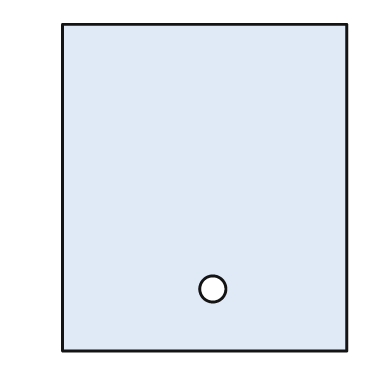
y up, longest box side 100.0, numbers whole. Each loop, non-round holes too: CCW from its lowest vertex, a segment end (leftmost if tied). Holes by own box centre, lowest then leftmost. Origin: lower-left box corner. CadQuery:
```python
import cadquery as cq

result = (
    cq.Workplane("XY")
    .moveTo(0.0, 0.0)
    .lineTo(87.0, 0.0)
    .lineTo(87.0, 100.0)
    .lineTo(0.0, 100.0)
    .close()
    .moveTo(46.0, 19.0)
    .circle(4.0)
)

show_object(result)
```